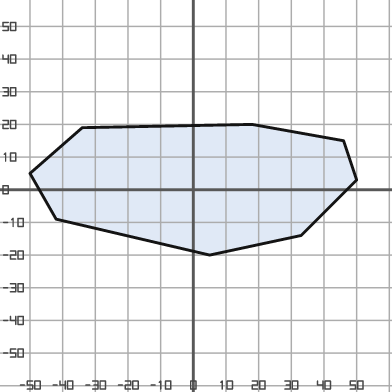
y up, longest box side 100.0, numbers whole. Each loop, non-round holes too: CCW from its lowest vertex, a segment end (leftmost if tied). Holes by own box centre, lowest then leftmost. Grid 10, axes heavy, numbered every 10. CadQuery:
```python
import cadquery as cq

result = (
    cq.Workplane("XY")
    .moveTo(5.0, -20.0)
    .lineTo(33.0, -14.0)
    .lineTo(50.0, 3.0)
    .lineTo(46.0, 15.0)
    .lineTo(18.0, 20.0)
    .lineTo(-34.0, 19.0)
    .lineTo(-50.0, 5.0)
    .lineTo(-42.0, -9.0)
    .close()
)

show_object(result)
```